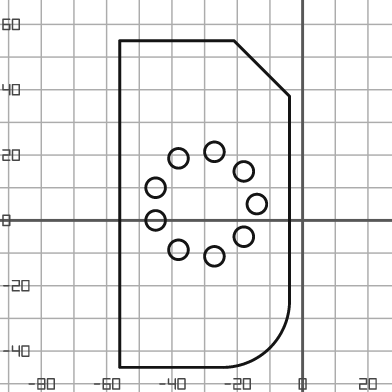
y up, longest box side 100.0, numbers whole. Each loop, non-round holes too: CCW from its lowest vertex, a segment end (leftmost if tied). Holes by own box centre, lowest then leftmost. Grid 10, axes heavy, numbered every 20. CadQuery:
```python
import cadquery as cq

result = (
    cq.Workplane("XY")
    .moveTo(-56.0, -45.0)
    .lineTo(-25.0, -45.0)
    .threePointArc((-10.0, -39.0), (-4.0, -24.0))
    .lineTo(-4.0, 38.0)
    .lineTo(-21.0, 55.0)
    .lineTo(-56.0, 55.0)
    .close()
    .moveTo(-27.0, -11.0)
    .circle(3.0)
    .moveTo(-38.0, -9.0)
    .circle(3.0)
    .moveTo(-18.0, -5.0)
    .circle(3.0)
    .moveTo(-45.0, 0.0)
    .circle(3.0)
    .moveTo(-14.0, 5.0)
    .circle(3.0)
    .moveTo(-45.0, 10.0)
    .circle(3.0)
    .moveTo(-18.0, 15.0)
    .circle(3.0)
    .moveTo(-38.0, 19.0)
    .circle(3.0)
    .moveTo(-27.0, 21.0)
    .circle(3.0)
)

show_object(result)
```